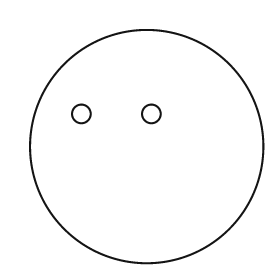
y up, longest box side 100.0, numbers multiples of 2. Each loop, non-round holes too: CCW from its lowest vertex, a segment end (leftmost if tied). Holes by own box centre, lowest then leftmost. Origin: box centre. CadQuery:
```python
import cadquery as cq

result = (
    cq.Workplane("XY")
    .moveTo(0.0, 0.0)
    .circle(50.0)
    .moveTo(-28.0, 14.0)
    .circle(4.0)
    .moveTo(2.0, 14.0)
    .circle(4.0)
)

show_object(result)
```